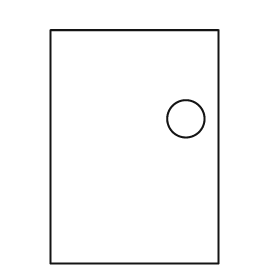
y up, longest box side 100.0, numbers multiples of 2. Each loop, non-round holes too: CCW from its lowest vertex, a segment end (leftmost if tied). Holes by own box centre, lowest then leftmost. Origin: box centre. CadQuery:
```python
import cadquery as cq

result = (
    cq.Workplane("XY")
    .moveTo(-36.0, -50.0)
    .lineTo(36.0, -50.0)
    .lineTo(36.0, 50.0)
    .lineTo(-36.0, 50.0)
    .close()
    .moveTo(22.0, 12.0)
    .circle(8.0)
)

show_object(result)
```